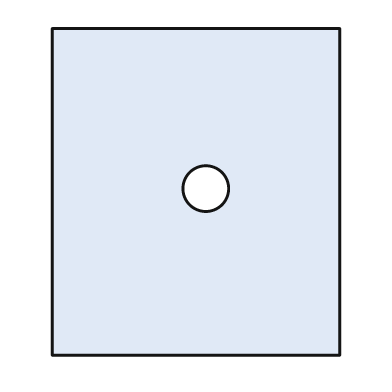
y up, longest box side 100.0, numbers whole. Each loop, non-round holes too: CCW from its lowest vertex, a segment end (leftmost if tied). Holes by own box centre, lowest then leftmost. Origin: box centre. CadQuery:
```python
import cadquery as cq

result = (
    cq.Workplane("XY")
    .moveTo(-44.0, -50.0)
    .lineTo(44.0, -50.0)
    .lineTo(44.0, 50.0)
    .lineTo(-44.0, 50.0)
    .close()
    .moveTo(3.0, 1.0)
    .circle(7.0)
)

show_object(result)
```